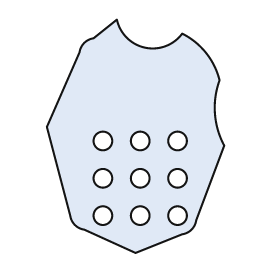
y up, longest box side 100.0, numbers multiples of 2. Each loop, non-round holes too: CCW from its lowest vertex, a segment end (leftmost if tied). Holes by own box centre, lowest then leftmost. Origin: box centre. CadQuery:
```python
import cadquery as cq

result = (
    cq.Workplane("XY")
    .moveTo(0.0, -50.0)
    .lineTo(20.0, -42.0)
    .threePointArc((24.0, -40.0), (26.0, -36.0))
    .lineTo(38.0, -4.0)
    .threePointArc((34.0, 10.0), (36.0, 24.0))
    .threePointArc((30.0, 36.0), (20.0, 44.0))
    .threePointArc((4.0, 38.0), (-8.0, 50.0))
    .lineTo(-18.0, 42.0)
    .threePointArc((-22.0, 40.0), (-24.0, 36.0))
    .lineTo(-38.0, 4.0)
    .lineTo(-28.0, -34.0)
    .threePointArc((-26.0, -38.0), (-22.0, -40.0))
    .close()
    .moveTo(-14.0, -34.0)
    .circle(4.0)
    .moveTo(2.0, -34.0)
    .circle(4.0)
    .moveTo(18.0, -34.0)
    .circle(4.0)
    .moveTo(-14.0, -18.0)
    .circle(4.0)
    .moveTo(2.0, -18.0)
    .circle(4.0)
    .moveTo(18.0, -18.0)
    .circle(4.0)
    .moveTo(-14.0, -2.0)
    .circle(4.0)
    .moveTo(2.0, -2.0)
    .circle(4.0)
    .moveTo(18.0, -2.0)
    .circle(4.0)
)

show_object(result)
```